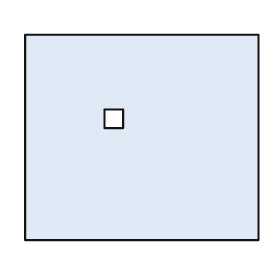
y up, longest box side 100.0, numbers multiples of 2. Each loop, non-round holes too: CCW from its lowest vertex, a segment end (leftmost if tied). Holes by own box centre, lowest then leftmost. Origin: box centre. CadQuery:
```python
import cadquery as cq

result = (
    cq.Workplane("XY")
    .moveTo(-50.0, -44.0)
    .lineTo(50.0, -44.0)
    .lineTo(50.0, 44.0)
    .lineTo(-50.0, 44.0)
    .close()
    .moveTo(-16.0, 4.0)
    .lineTo(-8.0, 4.0)
    .lineTo(-8.0, 12.0)
    .lineTo(-16.0, 12.0)
    .close()
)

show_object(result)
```